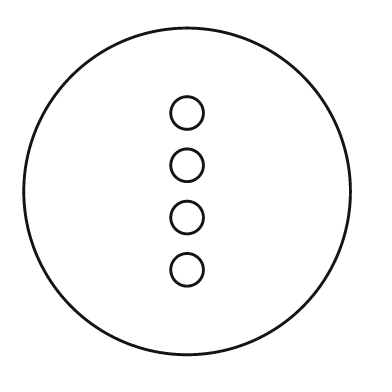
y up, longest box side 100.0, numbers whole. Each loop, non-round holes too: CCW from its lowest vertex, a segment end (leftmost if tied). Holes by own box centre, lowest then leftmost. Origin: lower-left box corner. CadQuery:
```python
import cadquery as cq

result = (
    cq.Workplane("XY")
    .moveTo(50.0, 50.0)
    .circle(50.0)
    .moveTo(50.0, 26.0)
    .circle(5.0)
    .moveTo(50.0, 42.0)
    .circle(5.0)
    .moveTo(50.0, 58.0)
    .circle(5.0)
    .moveTo(50.0, 74.0)
    .circle(5.0)
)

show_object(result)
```